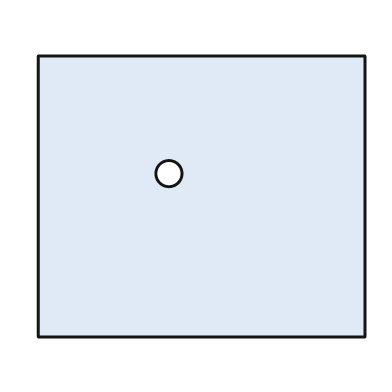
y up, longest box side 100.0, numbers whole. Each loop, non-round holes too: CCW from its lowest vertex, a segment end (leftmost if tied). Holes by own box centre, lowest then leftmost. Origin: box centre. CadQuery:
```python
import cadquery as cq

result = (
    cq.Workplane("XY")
    .moveTo(-50.0, -43.0)
    .lineTo(50.0, -43.0)
    .lineTo(50.0, 43.0)
    .lineTo(-50.0, 43.0)
    .close()
    .moveTo(-10.0, 7.0)
    .circle(4.0)
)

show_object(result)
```